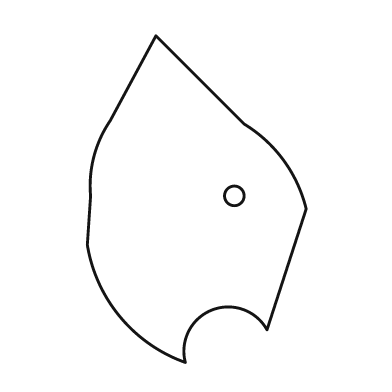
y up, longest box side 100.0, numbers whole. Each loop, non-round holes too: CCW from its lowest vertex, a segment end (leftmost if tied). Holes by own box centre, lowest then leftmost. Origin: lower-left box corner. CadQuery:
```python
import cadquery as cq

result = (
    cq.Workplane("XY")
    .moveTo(30.0, 0.0)
    .threePointArc((38.0, 16.0), (55.0, 10.0))
    .lineTo(67.0, 47.0)
    .threePointArc((60.0, 62.0), (48.0, 73.0))
    .lineTo(21.0, 100.0)
    .lineTo(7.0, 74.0)
    .threePointArc((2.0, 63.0), (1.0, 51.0))
    .lineTo(0.0, 36.0)
    .threePointArc((10.0, 14.0), (30.0, 0.0))
    .close()
    .moveTo(45.0, 51.0)
    .circle(3.0)
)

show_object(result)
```